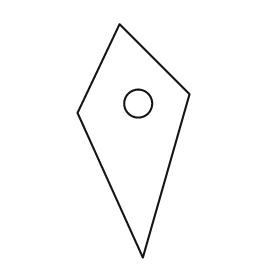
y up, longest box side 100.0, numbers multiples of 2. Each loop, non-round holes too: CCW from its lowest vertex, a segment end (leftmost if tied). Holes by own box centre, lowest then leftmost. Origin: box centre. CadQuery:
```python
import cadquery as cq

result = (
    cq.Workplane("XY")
    .moveTo(4.0, -50.0)
    .lineTo(24.0, 20.0)
    .lineTo(-6.0, 50.0)
    .lineTo(-24.0, 12.0)
    .close()
    .moveTo(2.0, 16.0)
    .circle(6.0)
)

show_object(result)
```